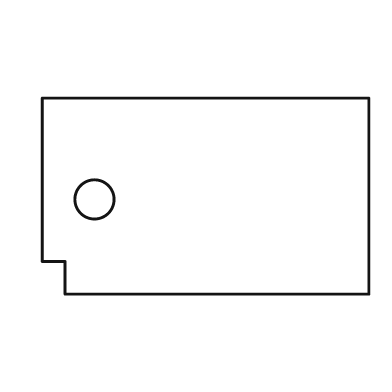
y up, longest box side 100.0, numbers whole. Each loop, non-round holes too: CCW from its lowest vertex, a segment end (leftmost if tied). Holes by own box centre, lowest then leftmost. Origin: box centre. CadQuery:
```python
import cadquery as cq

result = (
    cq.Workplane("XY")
    .moveTo(-43.0, -30.0)
    .lineTo(50.0, -30.0)
    .lineTo(50.0, 30.0)
    .lineTo(-50.0, 30.0)
    .lineTo(-50.0, -20.0)
    .lineTo(-43.0, -20.0)
    .close()
    .moveTo(-34.0, -1.0)
    .circle(6.0)
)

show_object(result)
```